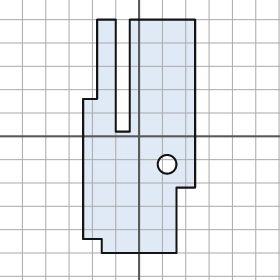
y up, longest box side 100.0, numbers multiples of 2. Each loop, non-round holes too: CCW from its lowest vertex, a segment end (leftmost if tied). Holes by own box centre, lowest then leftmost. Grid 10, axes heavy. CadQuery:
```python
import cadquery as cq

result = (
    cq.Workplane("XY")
    .moveTo(-16.0, -50.0)
    .lineTo(16.0, -50.0)
    .lineTo(16.0, -22.0)
    .lineTo(24.0, -22.0)
    .lineTo(24.0, 50.0)
    .lineTo(-4.0, 50.0)
    .lineTo(-4.0, 2.0)
    .lineTo(-10.0, 2.0)
    .lineTo(-10.0, 50.0)
    .lineTo(-18.0, 50.0)
    .lineTo(-18.0, 16.0)
    .lineTo(-24.0, 16.0)
    .lineTo(-24.0, -44.0)
    .lineTo(-16.0, -44.0)
    .close()
    .moveTo(12.0, -12.0)
    .circle(4.0)
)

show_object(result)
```